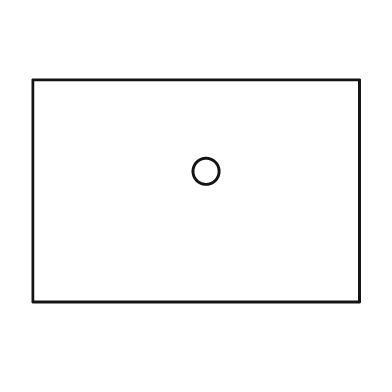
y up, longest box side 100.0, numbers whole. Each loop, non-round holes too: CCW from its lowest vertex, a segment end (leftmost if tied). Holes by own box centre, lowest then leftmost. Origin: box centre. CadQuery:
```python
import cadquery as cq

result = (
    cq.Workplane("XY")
    .moveTo(-50.0, -34.0)
    .lineTo(50.0, -34.0)
    .lineTo(50.0, 34.0)
    .lineTo(-50.0, 34.0)
    .close()
    .moveTo(3.0, 6.0)
    .circle(4.0)
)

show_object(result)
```